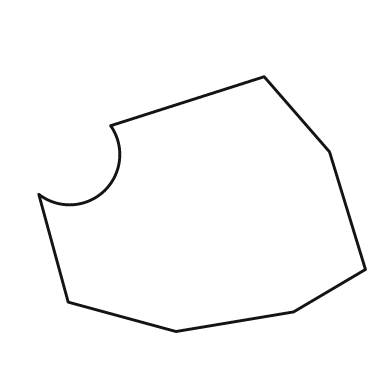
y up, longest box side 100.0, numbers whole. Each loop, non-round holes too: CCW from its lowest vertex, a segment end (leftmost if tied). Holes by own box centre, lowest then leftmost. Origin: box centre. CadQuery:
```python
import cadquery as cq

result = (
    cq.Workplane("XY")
    .moveTo(-8.0, -39.0)
    .lineTo(28.0, -33.0)
    .lineTo(50.0, -20.0)
    .lineTo(39.0, 16.0)
    .lineTo(19.0, 39.0)
    .lineTo(-28.0, 24.0)
    .threePointArc((-30.0, 4.0), (-50.0, 3.0))
    .lineTo(-41.0, -30.0)
    .close()
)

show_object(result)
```